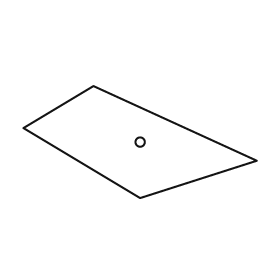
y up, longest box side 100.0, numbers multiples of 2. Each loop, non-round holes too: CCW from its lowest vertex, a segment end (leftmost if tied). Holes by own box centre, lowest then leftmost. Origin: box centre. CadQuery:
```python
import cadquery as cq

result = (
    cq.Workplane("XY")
    .moveTo(0.0, -24.0)
    .lineTo(50.0, -8.0)
    .lineTo(-20.0, 24.0)
    .lineTo(-50.0, 6.0)
    .close()
    .moveTo(0.0, 0.0)
    .circle(2.0)
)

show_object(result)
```